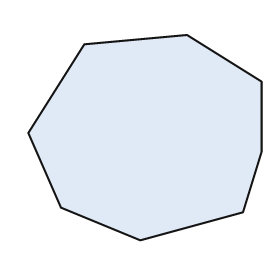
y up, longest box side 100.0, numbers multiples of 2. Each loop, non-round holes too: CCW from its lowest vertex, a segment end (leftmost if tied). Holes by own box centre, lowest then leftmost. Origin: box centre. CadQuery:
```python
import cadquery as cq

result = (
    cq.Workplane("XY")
    .moveTo(-2.0, -44.0)
    .lineTo(42.0, -32.0)
    .lineTo(50.0, -6.0)
    .lineTo(50.0, 24.0)
    .lineTo(18.0, 44.0)
    .lineTo(-26.0, 40.0)
    .lineTo(-50.0, 2.0)
    .lineTo(-36.0, -30.0)
    .close()
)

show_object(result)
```